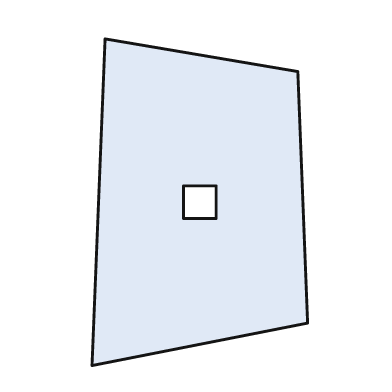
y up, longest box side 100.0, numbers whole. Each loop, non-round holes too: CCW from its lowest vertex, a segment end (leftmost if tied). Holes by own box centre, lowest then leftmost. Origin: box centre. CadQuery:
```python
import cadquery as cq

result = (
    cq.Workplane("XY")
    .moveTo(-33.0, -50.0)
    .lineTo(33.0, -37.0)
    .lineTo(30.0, 40.0)
    .lineTo(-29.0, 50.0)
    .close()
    .moveTo(-5.0, -5.0)
    .lineTo(5.0, -5.0)
    .lineTo(5.0, 5.0)
    .lineTo(-5.0, 5.0)
    .close()
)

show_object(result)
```